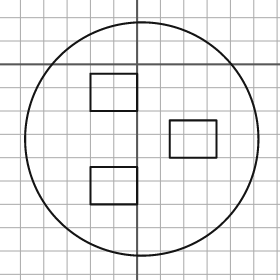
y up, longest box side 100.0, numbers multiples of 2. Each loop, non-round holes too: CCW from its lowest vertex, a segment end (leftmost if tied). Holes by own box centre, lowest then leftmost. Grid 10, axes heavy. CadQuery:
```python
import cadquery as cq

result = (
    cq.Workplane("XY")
    .moveTo(2.0, -32.0)
    .circle(50.0)
    .moveTo(-20.0, -60.0)
    .lineTo(0.0, -60.0)
    .lineTo(0.0, -44.0)
    .lineTo(-20.0, -44.0)
    .close()
    .moveTo(14.0, -40.0)
    .lineTo(34.0, -40.0)
    .lineTo(34.0, -24.0)
    .lineTo(14.0, -24.0)
    .close()
    .moveTo(-20.0, -20.0)
    .lineTo(0.0, -20.0)
    .lineTo(0.0, -4.0)
    .lineTo(-20.0, -4.0)
    .close()
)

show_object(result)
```